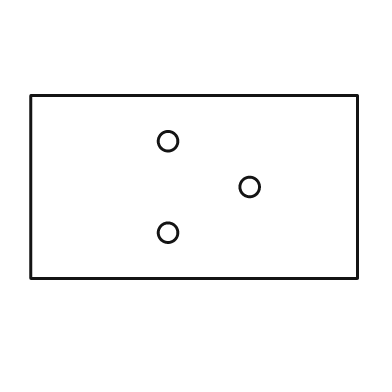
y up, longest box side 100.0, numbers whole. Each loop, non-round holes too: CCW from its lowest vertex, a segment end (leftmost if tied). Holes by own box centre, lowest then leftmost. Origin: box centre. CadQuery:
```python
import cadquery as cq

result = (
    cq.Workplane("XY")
    .moveTo(-50.0, -28.0)
    .lineTo(50.0, -28.0)
    .lineTo(50.0, 28.0)
    .lineTo(-50.0, 28.0)
    .close()
    .moveTo(-8.0, -14.0)
    .circle(3.0)
    .moveTo(17.0, 0.0)
    .circle(3.0)
    .moveTo(-8.0, 14.0)
    .circle(3.0)
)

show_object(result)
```